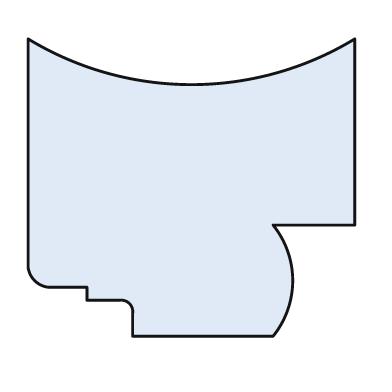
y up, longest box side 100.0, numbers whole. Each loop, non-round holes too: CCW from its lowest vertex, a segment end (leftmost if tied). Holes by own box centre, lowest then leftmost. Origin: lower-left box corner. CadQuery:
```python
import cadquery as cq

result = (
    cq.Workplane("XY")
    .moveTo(32.0, 0.0)
    .lineTo(75.0, 0.0)
    .threePointArc((81.0, 17.0), (75.0, 34.0))
    .lineTo(100.0, 34.0)
    .lineTo(100.0, 91.0)
    .threePointArc((50.0, 77.0), (0.0, 91.0))
    .lineTo(0.0, 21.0)
    .threePointArc((2.0, 17.0), (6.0, 15.0))
    .lineTo(18.0, 15.0)
    .lineTo(18.0, 11.0)
    .lineTo(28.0, 11.0)
    .threePointArc((31.0, 10.0), (32.0, 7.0))
    .close()
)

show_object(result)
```